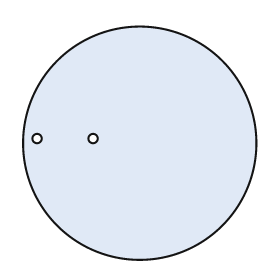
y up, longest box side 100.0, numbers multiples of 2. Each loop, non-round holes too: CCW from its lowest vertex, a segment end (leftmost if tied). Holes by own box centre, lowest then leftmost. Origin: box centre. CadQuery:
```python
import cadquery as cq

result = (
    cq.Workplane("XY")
    .moveTo(0.0, 0.0)
    .circle(50.0)
    .moveTo(-44.0, 2.0)
    .circle(2.0)
    .moveTo(-20.0, 2.0)
    .circle(2.0)
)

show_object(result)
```